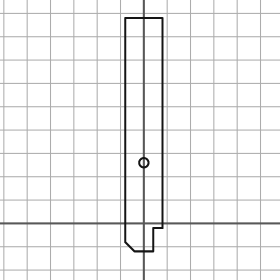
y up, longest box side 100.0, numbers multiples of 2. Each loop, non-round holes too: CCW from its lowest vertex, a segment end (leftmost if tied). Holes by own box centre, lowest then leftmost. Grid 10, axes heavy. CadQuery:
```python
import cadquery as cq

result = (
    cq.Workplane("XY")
    .moveTo(-4.0, -12.0)
    .lineTo(4.0, -12.0)
    .lineTo(4.0, -2.0)
    .lineTo(8.0, -2.0)
    .lineTo(8.0, 88.0)
    .lineTo(-8.0, 88.0)
    .lineTo(-8.0, -8.0)
    .close()
    .moveTo(0.0, 26.0)
    .circle(2.0)
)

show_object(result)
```